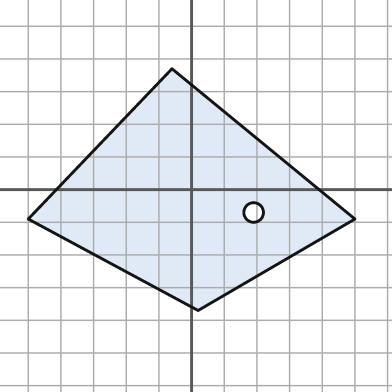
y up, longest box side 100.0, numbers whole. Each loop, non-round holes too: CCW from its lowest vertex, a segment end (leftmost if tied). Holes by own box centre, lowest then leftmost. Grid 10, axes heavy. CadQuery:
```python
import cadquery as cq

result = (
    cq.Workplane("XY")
    .moveTo(2.0, -37.0)
    .lineTo(50.0, -9.0)
    .lineTo(-6.0, 37.0)
    .lineTo(-50.0, -9.0)
    .close()
    .moveTo(19.0, -7.0)
    .circle(3.0)
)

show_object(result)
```